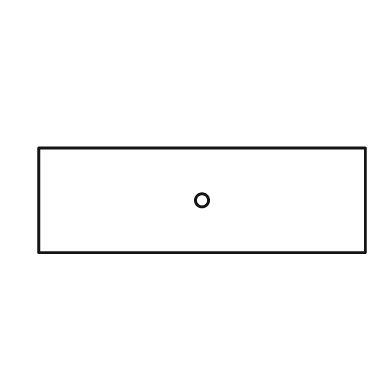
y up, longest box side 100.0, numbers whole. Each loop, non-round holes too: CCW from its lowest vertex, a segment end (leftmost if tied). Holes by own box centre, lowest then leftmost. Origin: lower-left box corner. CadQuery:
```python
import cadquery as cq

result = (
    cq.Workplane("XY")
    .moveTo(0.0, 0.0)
    .lineTo(100.0, 0.0)
    .lineTo(100.0, 32.0)
    .lineTo(0.0, 32.0)
    .close()
    .moveTo(50.0, 16.0)
    .circle(2.0)
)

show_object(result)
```